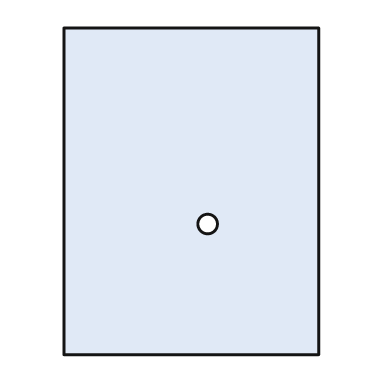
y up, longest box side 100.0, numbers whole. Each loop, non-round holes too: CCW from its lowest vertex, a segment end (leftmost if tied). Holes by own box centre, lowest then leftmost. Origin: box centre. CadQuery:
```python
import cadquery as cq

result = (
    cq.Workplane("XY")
    .moveTo(-39.0, -50.0)
    .lineTo(39.0, -50.0)
    .lineTo(39.0, 50.0)
    .lineTo(-39.0, 50.0)
    .close()
    .moveTo(5.0, -10.0)
    .circle(3.0)
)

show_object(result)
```